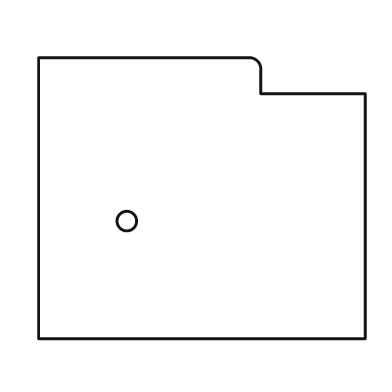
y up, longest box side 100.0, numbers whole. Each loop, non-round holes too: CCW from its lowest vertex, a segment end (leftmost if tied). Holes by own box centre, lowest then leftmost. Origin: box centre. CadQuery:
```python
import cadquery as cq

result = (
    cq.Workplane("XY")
    .moveTo(-50.0, -43.0)
    .lineTo(50.0, -43.0)
    .lineTo(50.0, 32.0)
    .lineTo(18.0, 32.0)
    .lineTo(18.0, 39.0)
    .threePointArc((17.0, 42.0), (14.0, 43.0))
    .lineTo(-50.0, 43.0)
    .close()
    .moveTo(-23.0, -7.0)
    .circle(3.0)
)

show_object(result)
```